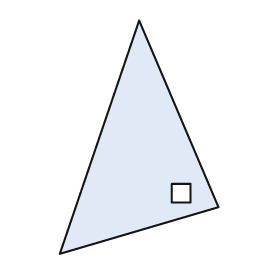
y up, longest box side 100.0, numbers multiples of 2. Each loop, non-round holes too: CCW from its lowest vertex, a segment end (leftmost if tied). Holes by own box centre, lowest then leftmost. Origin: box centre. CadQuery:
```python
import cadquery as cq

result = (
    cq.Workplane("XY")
    .moveTo(-34.0, -50.0)
    .lineTo(34.0, -30.0)
    .lineTo(0.0, 50.0)
    .close()
    .moveTo(14.0, -28.0)
    .lineTo(22.0, -28.0)
    .lineTo(22.0, -20.0)
    .lineTo(14.0, -20.0)
    .close()
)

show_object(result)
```